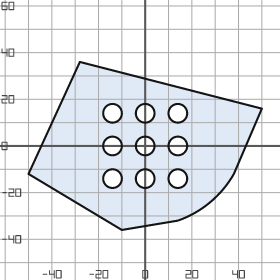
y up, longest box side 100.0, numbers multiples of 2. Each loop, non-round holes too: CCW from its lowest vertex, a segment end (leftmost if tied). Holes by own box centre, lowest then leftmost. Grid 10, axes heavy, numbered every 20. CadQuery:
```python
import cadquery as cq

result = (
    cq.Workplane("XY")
    .moveTo(-10.0, -36.0)
    .lineTo(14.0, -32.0)
    .threePointArc((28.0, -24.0), (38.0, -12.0))
    .lineTo(50.0, 16.0)
    .lineTo(-28.0, 36.0)
    .lineTo(-50.0, -12.0)
    .close()
    .moveTo(-14.0, -14.0)
    .circle(4.0)
    .moveTo(0.0, -14.0)
    .circle(4.0)
    .moveTo(14.0, -14.0)
    .circle(4.0)
    .moveTo(-14.0, 0.0)
    .circle(4.0)
    .moveTo(0.0, 0.0)
    .circle(4.0)
    .moveTo(14.0, 0.0)
    .circle(4.0)
    .moveTo(-14.0, 14.0)
    .circle(4.0)
    .moveTo(0.0, 14.0)
    .circle(4.0)
    .moveTo(14.0, 14.0)
    .circle(4.0)
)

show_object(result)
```